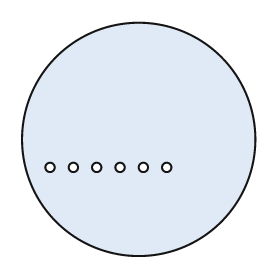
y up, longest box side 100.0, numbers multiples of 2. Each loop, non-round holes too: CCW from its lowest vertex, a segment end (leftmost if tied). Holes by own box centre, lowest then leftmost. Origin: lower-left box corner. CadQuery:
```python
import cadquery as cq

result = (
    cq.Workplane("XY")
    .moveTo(50.0, 50.0)
    .circle(50.0)
    .moveTo(12.0, 38.0)
    .circle(2.0)
    .moveTo(22.0, 38.0)
    .circle(2.0)
    .moveTo(32.0, 38.0)
    .circle(2.0)
    .moveTo(42.0, 38.0)
    .circle(2.0)
    .moveTo(52.0, 38.0)
    .circle(2.0)
    .moveTo(62.0, 38.0)
    .circle(2.0)
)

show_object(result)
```